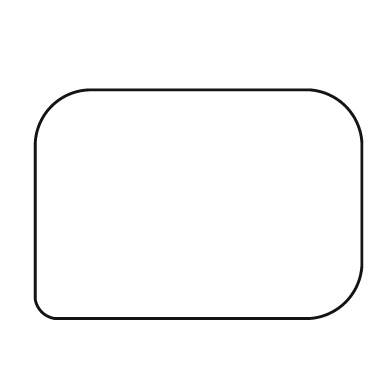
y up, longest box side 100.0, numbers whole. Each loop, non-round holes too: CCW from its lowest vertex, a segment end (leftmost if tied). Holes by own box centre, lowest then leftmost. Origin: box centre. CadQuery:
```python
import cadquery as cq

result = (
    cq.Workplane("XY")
    .moveTo(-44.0, -35.0)
    .lineTo(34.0, -35.0)
    .threePointArc((45.0, -30.0), (50.0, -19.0))
    .lineTo(50.0, 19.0)
    .threePointArc((45.0, 30.0), (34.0, 35.0))
    .lineTo(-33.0, 35.0)
    .threePointArc((-45.0, 30.0), (-50.0, 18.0))
    .lineTo(-50.0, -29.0)
    .threePointArc((-48.0, -33.0), (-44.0, -35.0))
    .close()
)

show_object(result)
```